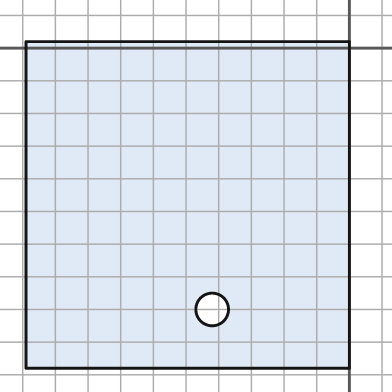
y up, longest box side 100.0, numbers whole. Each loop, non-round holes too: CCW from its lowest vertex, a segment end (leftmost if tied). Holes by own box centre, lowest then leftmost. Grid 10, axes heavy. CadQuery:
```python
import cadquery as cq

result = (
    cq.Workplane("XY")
    .moveTo(-99.0, -98.0)
    .lineTo(0.0, -98.0)
    .lineTo(0.0, 2.0)
    .lineTo(-99.0, 2.0)
    .close()
    .moveTo(-42.0, -80.0)
    .circle(5.0)
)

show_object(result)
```